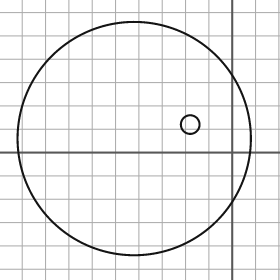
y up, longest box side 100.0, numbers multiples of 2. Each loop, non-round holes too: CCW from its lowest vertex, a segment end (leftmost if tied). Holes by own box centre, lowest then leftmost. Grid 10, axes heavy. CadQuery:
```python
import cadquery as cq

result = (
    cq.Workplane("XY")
    .moveTo(-42.0, 6.0)
    .circle(50.0)
    .moveTo(-18.0, 12.0)
    .circle(4.0)
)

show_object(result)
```